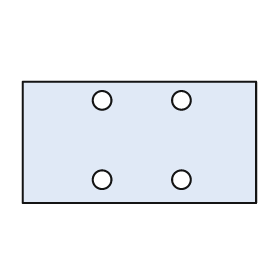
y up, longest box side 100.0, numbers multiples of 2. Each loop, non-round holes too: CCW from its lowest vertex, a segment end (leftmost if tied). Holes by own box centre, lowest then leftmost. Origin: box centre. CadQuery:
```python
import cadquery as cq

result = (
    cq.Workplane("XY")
    .moveTo(-50.0, -26.0)
    .lineTo(50.0, -26.0)
    .lineTo(50.0, 26.0)
    .lineTo(-50.0, 26.0)
    .close()
    .moveTo(-16.0, -16.0)
    .circle(4.0)
    .moveTo(18.0, -16.0)
    .circle(4.0)
    .moveTo(-16.0, 18.0)
    .circle(4.0)
    .moveTo(18.0, 18.0)
    .circle(4.0)
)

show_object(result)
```